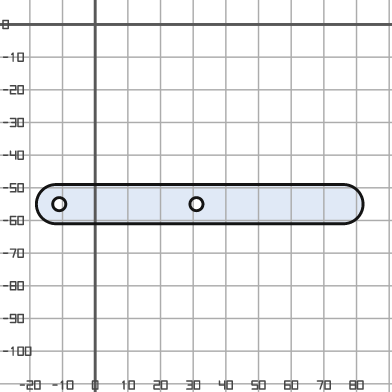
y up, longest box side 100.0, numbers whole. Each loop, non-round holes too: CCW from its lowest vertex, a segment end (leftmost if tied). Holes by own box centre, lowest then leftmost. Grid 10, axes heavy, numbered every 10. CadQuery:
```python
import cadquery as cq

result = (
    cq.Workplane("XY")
    .moveTo(-12.0, -61.0)
    .lineTo(76.0, -61.0)
    .threePointArc((82.0, -55.0), (76.0, -49.0))
    .lineTo(-12.0, -49.0)
    .threePointArc((-18.0, -55.0), (-12.0, -61.0))
    .close()
    .moveTo(-11.0, -55.0)
    .circle(2.0)
    .moveTo(31.0, -55.0)
    .circle(2.0)
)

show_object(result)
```